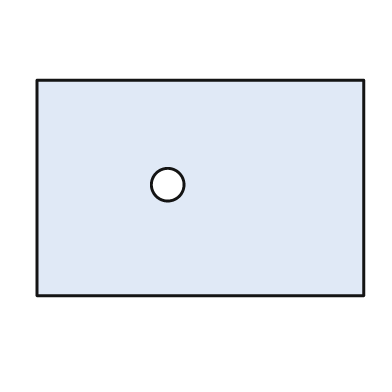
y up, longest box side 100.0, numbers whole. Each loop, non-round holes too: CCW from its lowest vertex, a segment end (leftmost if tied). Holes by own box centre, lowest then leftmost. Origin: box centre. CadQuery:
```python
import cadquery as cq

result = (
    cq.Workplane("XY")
    .moveTo(-50.0, -33.0)
    .lineTo(50.0, -33.0)
    .lineTo(50.0, 33.0)
    .lineTo(-50.0, 33.0)
    .close()
    .moveTo(-10.0, 1.0)
    .circle(5.0)
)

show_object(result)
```